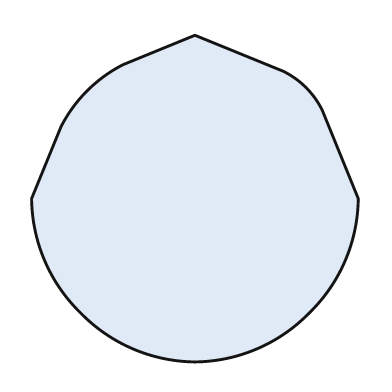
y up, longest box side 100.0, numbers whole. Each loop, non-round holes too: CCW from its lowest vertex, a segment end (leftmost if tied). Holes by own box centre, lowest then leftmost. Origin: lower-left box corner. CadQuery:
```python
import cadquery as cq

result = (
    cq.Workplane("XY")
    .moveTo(50.0, 0.0)
    .threePointArc((69.0, 4.0), (85.0, 15.0))
    .threePointArc((96.0, 31.0), (100.0, 50.0))
    .lineTo(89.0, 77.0)
    .threePointArc((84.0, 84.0), (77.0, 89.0))
    .lineTo(50.0, 100.0)
    .lineTo(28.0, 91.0)
    .threePointArc((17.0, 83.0), (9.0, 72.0))
    .lineTo(0.0, 50.0)
    .threePointArc((4.0, 31.0), (15.0, 15.0))
    .threePointArc((31.0, 4.0), (50.0, 0.0))
    .close()
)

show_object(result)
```